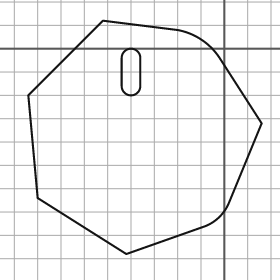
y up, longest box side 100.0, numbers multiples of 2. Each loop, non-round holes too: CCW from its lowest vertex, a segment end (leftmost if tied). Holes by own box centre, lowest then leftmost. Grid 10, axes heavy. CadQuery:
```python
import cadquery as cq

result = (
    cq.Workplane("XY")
    .moveTo(-42.0, -88.0)
    .lineTo(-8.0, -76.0)
    .threePointArc((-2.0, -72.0), (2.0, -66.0))
    .lineTo(16.0, -32.0)
    .lineTo(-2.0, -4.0)
    .threePointArc((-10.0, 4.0), (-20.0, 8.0))
    .lineTo(-52.0, 12.0)
    .lineTo(-84.0, -20.0)
    .lineTo(-80.0, -64.0)
    .close()
    .moveTo(-44.0, -16.0)
    .threePointArc((-40.0, -20.0), (-36.0, -16.0))
    .lineTo(-36.0, -4.0)
    .threePointArc((-40.0, 0.0), (-44.0, -4.0))
    .close()
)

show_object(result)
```